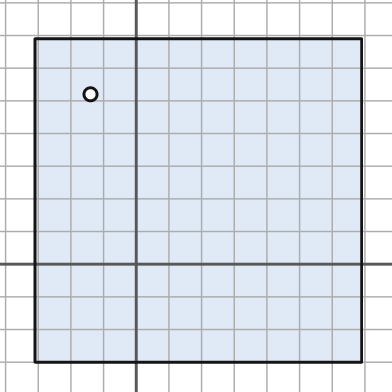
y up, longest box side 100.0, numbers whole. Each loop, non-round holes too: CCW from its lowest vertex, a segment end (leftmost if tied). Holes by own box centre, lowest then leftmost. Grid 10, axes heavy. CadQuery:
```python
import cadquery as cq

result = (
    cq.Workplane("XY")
    .moveTo(-31.0, -30.0)
    .lineTo(69.0, -30.0)
    .lineTo(69.0, 69.0)
    .lineTo(-31.0, 69.0)
    .close()
    .moveTo(-14.0, 52.0)
    .circle(2.0)
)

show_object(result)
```